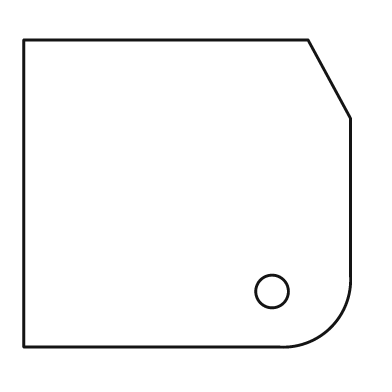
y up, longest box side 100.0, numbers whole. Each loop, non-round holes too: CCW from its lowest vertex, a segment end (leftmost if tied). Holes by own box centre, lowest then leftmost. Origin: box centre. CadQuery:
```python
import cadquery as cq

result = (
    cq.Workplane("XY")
    .moveTo(-50.0, -47.0)
    .lineTo(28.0, -47.0)
    .threePointArc((44.0, -41.0), (50.0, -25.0))
    .lineTo(50.0, 23.0)
    .lineTo(37.0, 47.0)
    .lineTo(-50.0, 47.0)
    .close()
    .moveTo(26.0, -30.0)
    .circle(5.0)
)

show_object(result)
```